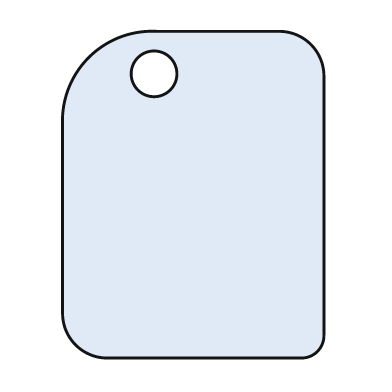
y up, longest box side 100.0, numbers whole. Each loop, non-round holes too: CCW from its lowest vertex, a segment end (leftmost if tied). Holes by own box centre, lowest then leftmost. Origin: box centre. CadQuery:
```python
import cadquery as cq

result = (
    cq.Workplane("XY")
    .moveTo(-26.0, -50.0)
    .lineTo(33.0, -50.0)
    .threePointArc((38.0, -48.0), (40.0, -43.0))
    .lineTo(40.0, 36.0)
    .threePointArc((36.0, 46.0), (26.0, 50.0))
    .lineTo(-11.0, 50.0)
    .threePointArc((-32.0, 42.0), (-40.0, 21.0))
    .lineTo(-40.0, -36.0)
    .threePointArc((-36.0, -46.0), (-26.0, -50.0))
    .close()
    .moveTo(-12.0, 37.0)
    .circle(7.0)
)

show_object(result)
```